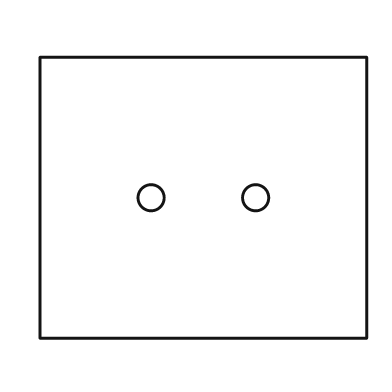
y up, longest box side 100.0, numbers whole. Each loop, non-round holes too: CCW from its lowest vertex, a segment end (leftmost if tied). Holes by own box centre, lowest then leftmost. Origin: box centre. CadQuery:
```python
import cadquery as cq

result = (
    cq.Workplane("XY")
    .moveTo(-50.0, -43.0)
    .lineTo(50.0, -43.0)
    .lineTo(50.0, 43.0)
    .lineTo(-50.0, 43.0)
    .close()
    .moveTo(-16.0, 0.0)
    .circle(4.0)
    .moveTo(16.0, 0.0)
    .circle(4.0)
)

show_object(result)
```